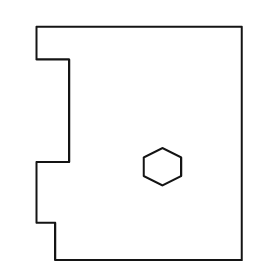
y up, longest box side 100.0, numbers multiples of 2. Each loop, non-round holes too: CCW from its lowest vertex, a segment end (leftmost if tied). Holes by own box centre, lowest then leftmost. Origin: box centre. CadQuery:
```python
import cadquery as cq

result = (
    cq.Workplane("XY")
    .moveTo(-36.0, -50.0)
    .lineTo(44.0, -50.0)
    .lineTo(44.0, 50.0)
    .lineTo(-44.0, 50.0)
    .lineTo(-44.0, 36.0)
    .lineTo(-30.0, 36.0)
    .lineTo(-30.0, -8.0)
    .lineTo(-44.0, -8.0)
    .lineTo(-44.0, -34.0)
    .lineTo(-36.0, -34.0)
    .close()
    .moveTo(10.0, -18.0)
    .lineTo(18.0, -14.0)
    .lineTo(18.0, -6.0)
    .lineTo(10.0, -2.0)
    .lineTo(2.0, -6.0)
    .lineTo(2.0, -14.0)
    .close()
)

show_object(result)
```